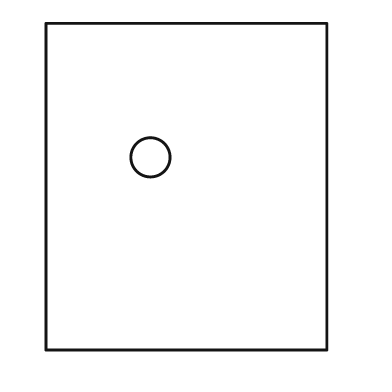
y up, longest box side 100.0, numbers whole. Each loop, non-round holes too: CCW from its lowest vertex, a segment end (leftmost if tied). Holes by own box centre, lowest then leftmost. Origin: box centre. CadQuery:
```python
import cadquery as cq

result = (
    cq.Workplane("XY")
    .moveTo(-43.0, -50.0)
    .lineTo(43.0, -50.0)
    .lineTo(43.0, 50.0)
    .lineTo(-43.0, 50.0)
    .close()
    .moveTo(-11.0, 9.0)
    .circle(6.0)
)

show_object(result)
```